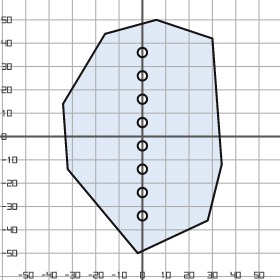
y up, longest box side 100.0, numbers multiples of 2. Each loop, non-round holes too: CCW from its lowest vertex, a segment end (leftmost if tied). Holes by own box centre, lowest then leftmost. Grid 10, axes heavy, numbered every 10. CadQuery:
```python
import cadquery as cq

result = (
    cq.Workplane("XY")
    .moveTo(-2.0, -50.0)
    .lineTo(28.0, -36.0)
    .lineTo(34.0, -12.0)
    .lineTo(30.0, 42.0)
    .lineTo(6.0, 50.0)
    .lineTo(-16.0, 44.0)
    .lineTo(-34.0, 14.0)
    .lineTo(-32.0, -14.0)
    .close()
    .moveTo(0.0, -34.0)
    .circle(2.0)
    .moveTo(0.0, -24.0)
    .circle(2.0)
    .moveTo(0.0, -14.0)
    .circle(2.0)
    .moveTo(0.0, -4.0)
    .circle(2.0)
    .moveTo(0.0, 6.0)
    .circle(2.0)
    .moveTo(0.0, 16.0)
    .circle(2.0)
    .moveTo(0.0, 26.0)
    .circle(2.0)
    .moveTo(0.0, 36.0)
    .circle(2.0)
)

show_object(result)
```